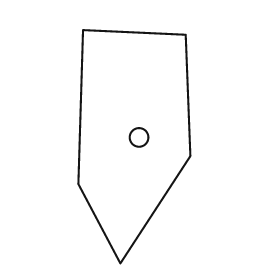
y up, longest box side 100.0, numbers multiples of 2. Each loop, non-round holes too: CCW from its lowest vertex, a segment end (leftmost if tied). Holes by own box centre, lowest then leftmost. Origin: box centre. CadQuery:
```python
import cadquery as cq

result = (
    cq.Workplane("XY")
    .moveTo(-6.0, -50.0)
    .lineTo(24.0, -4.0)
    .lineTo(22.0, 48.0)
    .lineTo(-22.0, 50.0)
    .lineTo(-24.0, -16.0)
    .close()
    .moveTo(2.0, 4.0)
    .circle(4.0)
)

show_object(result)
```